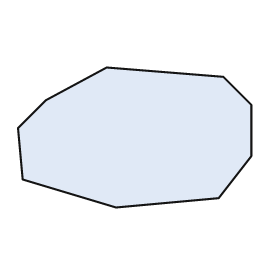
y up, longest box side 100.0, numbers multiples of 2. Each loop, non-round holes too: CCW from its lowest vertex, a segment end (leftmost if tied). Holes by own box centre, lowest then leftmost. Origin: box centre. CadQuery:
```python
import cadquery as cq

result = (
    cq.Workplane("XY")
    .moveTo(-8.0, -30.0)
    .lineTo(36.0, -26.0)
    .lineTo(50.0, -8.0)
    .lineTo(50.0, 14.0)
    .lineTo(38.0, 26.0)
    .lineTo(-12.0, 30.0)
    .lineTo(-38.0, 16.0)
    .lineTo(-50.0, 4.0)
    .lineTo(-48.0, -18.0)
    .close()
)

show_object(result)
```